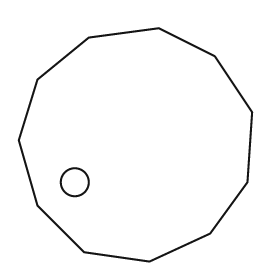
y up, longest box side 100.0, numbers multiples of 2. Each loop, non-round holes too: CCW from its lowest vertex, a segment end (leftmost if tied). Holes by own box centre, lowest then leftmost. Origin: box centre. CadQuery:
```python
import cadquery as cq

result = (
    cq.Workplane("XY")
    .moveTo(6.0, -50.0)
    .lineTo(32.0, -38.0)
    .lineTo(48.0, -16.0)
    .lineTo(50.0, 14.0)
    .lineTo(34.0, 38.0)
    .lineTo(10.0, 50.0)
    .lineTo(-20.0, 46.0)
    .lineTo(-42.0, 28.0)
    .lineTo(-50.0, 2.0)
    .lineTo(-42.0, -26.0)
    .lineTo(-22.0, -46.0)
    .close()
    .moveTo(-26.0, -16.0)
    .circle(6.0)
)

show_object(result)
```